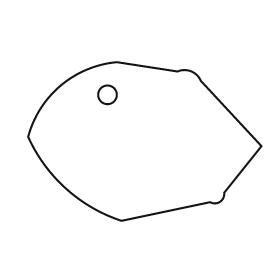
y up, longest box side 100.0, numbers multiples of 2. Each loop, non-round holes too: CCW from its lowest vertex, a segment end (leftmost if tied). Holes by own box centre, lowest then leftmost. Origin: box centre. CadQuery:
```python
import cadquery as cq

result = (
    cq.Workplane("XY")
    .moveTo(-10.0, -34.0)
    .lineTo(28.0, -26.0)
    .threePointArc((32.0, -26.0), (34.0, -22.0))
    .lineTo(50.0, -2.0)
    .lineTo(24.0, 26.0)
    .threePointArc((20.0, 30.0), (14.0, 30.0))
    .lineTo(-12.0, 34.0)
    .threePointArc((-36.0, 24.0), (-50.0, 2.0))
    .threePointArc((-34.0, -20.0), (-10.0, -34.0))
    .close()
    .moveTo(-16.0, 20.0)
    .circle(4.0)
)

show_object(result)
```